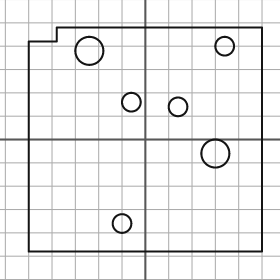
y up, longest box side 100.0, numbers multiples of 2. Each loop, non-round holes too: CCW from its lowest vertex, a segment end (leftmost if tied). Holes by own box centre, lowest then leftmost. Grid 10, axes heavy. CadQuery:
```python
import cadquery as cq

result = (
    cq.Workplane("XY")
    .moveTo(-50.0, -48.0)
    .lineTo(50.0, -48.0)
    .lineTo(50.0, 48.0)
    .lineTo(-38.0, 48.0)
    .lineTo(-38.0, 42.0)
    .lineTo(-50.0, 42.0)
    .close()
    .moveTo(-10.0, -36.0)
    .circle(4.0)
    .moveTo(30.0, -6.0)
    .circle(6.0)
    .moveTo(14.0, 14.0)
    .circle(4.0)
    .moveTo(-6.0, 16.0)
    .circle(4.0)
    .moveTo(-24.0, 38.0)
    .circle(6.0)
    .moveTo(34.0, 40.0)
    .circle(4.0)
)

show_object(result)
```